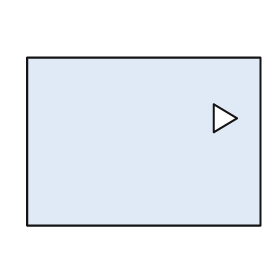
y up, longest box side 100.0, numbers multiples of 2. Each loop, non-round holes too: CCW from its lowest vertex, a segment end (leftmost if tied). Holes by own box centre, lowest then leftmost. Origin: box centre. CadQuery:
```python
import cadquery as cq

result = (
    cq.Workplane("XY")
    .moveTo(-50.0, -36.0)
    .lineTo(50.0, -36.0)
    .lineTo(50.0, 36.0)
    .lineTo(-50.0, 36.0)
    .close()
    .moveTo(30.0, 4.0)
    .lineTo(40.0, 10.0)
    .lineTo(30.0, 16.0)
    .close()
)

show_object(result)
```